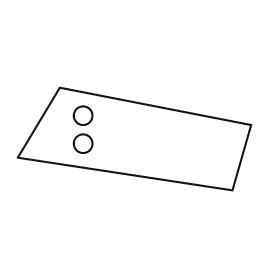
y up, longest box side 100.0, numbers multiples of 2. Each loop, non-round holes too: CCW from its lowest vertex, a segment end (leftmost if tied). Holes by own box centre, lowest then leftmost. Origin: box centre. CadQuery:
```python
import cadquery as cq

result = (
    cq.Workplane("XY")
    .moveTo(42.0, -22.0)
    .lineTo(50.0, 6.0)
    .lineTo(-32.0, 22.0)
    .lineTo(-50.0, -8.0)
    .close()
    .moveTo(-22.0, -2.0)
    .circle(4.0)
    .moveTo(-22.0, 10.0)
    .circle(4.0)
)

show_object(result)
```